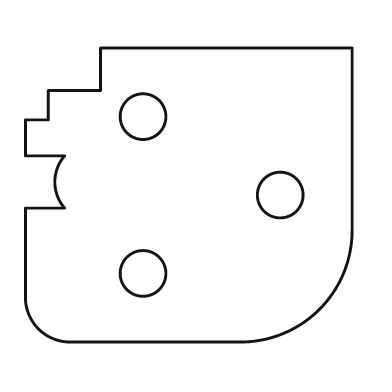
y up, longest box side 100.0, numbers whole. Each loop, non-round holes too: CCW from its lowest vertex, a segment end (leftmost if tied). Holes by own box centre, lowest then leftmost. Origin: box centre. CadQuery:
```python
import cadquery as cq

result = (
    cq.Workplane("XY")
    .moveTo(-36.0, -45.0)
    .lineTo(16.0, -45.0)
    .threePointArc((40.0, -35.0), (50.0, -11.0))
    .lineTo(50.0, 45.0)
    .lineTo(-27.0, 45.0)
    .lineTo(-27.0, 32.0)
    .lineTo(-43.0, 32.0)
    .lineTo(-43.0, 23.0)
    .lineTo(-50.0, 23.0)
    .lineTo(-50.0, 12.0)
    .lineTo(-38.0, 12.0)
    .threePointArc((-41.0, 4.0), (-38.0, -4.0))
    .lineTo(-50.0, -4.0)
    .lineTo(-50.0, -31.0)
    .threePointArc((-46.0, -41.0), (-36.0, -45.0))
    .close()
    .moveTo(-14.0, -24.0)
    .circle(7.0)
    .moveTo(28.0, 0.0)
    .circle(7.0)
    .moveTo(-14.0, 24.0)
    .circle(7.0)
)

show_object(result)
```